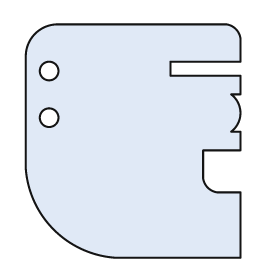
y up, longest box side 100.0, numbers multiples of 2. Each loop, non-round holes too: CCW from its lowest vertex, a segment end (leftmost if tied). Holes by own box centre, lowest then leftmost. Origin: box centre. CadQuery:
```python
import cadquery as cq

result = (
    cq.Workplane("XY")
    .moveTo(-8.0, -50.0)
    .lineTo(46.0, -50.0)
    .lineTo(46.0, -22.0)
    .lineTo(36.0, -22.0)
    .threePointArc((32.0, -20.0), (30.0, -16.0))
    .lineTo(30.0, -4.0)
    .lineTo(46.0, -4.0)
    .lineTo(46.0, 4.0)
    .lineTo(42.0, 4.0)
    .threePointArc((46.0, 12.0), (42.0, 20.0))
    .lineTo(46.0, 20.0)
    .lineTo(46.0, 28.0)
    .lineTo(16.0, 28.0)
    .lineTo(16.0, 34.0)
    .lineTo(46.0, 34.0)
    .lineTo(46.0, 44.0)
    .threePointArc((44.0, 48.0), (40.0, 50.0))
    .lineTo(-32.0, 50.0)
    .threePointArc((-42.0, 46.0), (-46.0, 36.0))
    .lineTo(-46.0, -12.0)
    .threePointArc((-34.0, -38.0), (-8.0, -50.0))
    .close()
    .moveTo(-36.0, 10.0)
    .circle(4.0)
    .moveTo(-36.0, 30.0)
    .circle(4.0)
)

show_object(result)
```